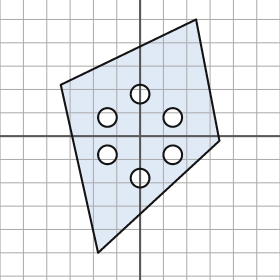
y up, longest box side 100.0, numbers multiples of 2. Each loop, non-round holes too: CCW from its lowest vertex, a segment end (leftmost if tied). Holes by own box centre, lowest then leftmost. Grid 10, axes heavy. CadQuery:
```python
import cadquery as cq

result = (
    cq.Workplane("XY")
    .moveTo(-18.0, -50.0)
    .lineTo(34.0, -2.0)
    .lineTo(24.0, 50.0)
    .lineTo(-34.0, 22.0)
    .close()
    .moveTo(0.0, -18.0)
    .circle(4.0)
    .moveTo(-14.0, -8.0)
    .circle(4.0)
    .moveTo(14.0, -8.0)
    .circle(4.0)
    .moveTo(-14.0, 8.0)
    .circle(4.0)
    .moveTo(14.0, 8.0)
    .circle(4.0)
    .moveTo(0.0, 18.0)
    .circle(4.0)
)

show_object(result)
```